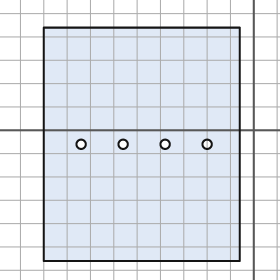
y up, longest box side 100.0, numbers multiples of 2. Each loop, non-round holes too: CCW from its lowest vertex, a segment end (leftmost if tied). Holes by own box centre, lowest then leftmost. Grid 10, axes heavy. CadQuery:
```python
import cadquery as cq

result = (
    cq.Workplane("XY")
    .moveTo(-90.0, -56.0)
    .lineTo(-6.0, -56.0)
    .lineTo(-6.0, 44.0)
    .lineTo(-90.0, 44.0)
    .close()
    .moveTo(-74.0, -6.0)
    .circle(2.0)
    .moveTo(-56.0, -6.0)
    .circle(2.0)
    .moveTo(-38.0, -6.0)
    .circle(2.0)
    .moveTo(-20.0, -6.0)
    .circle(2.0)
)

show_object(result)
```